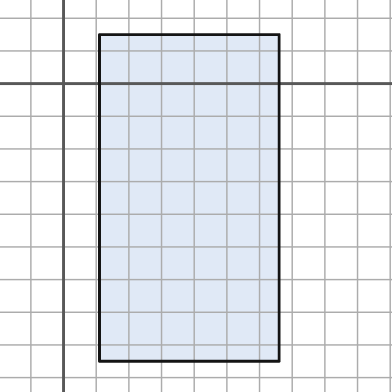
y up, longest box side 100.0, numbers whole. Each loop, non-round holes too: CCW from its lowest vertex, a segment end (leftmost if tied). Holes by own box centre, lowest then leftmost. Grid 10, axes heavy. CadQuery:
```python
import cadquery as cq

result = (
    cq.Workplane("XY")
    .moveTo(11.0, -85.0)
    .lineTo(66.0, -85.0)
    .lineTo(66.0, 15.0)
    .lineTo(11.0, 15.0)
    .close()
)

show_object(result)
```